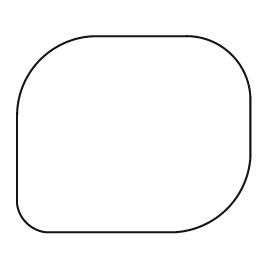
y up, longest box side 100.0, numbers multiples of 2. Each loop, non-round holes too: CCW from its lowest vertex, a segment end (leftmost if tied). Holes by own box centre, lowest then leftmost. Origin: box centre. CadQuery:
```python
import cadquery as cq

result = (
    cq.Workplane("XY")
    .moveTo(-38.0, -42.0)
    .lineTo(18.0, -42.0)
    .threePointArc((40.0, -32.0), (50.0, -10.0))
    .lineTo(50.0, 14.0)
    .threePointArc((42.0, 34.0), (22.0, 42.0))
    .lineTo(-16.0, 42.0)
    .threePointArc((-40.0, 32.0), (-50.0, 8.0))
    .lineTo(-50.0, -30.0)
    .threePointArc((-46.0, -38.0), (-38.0, -42.0))
    .close()
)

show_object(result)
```